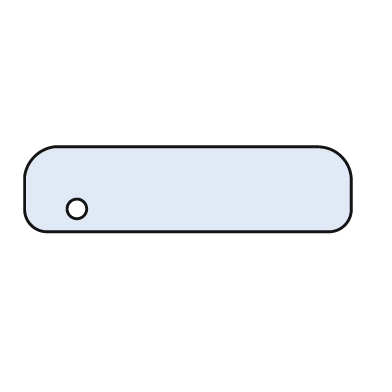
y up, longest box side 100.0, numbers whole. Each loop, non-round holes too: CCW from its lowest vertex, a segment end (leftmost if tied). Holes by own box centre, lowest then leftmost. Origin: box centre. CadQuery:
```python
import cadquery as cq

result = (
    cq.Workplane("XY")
    .moveTo(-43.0, -13.0)
    .lineTo(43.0, -13.0)
    .threePointArc((48.0, -11.0), (50.0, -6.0))
    .lineTo(50.0, 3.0)
    .threePointArc((47.0, 10.0), (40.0, 13.0))
    .lineTo(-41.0, 13.0)
    .threePointArc((-47.0, 10.0), (-50.0, 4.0))
    .lineTo(-50.0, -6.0)
    .threePointArc((-48.0, -11.0), (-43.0, -13.0))
    .close()
    .moveTo(-34.0, -6.0)
    .circle(3.0)
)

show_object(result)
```